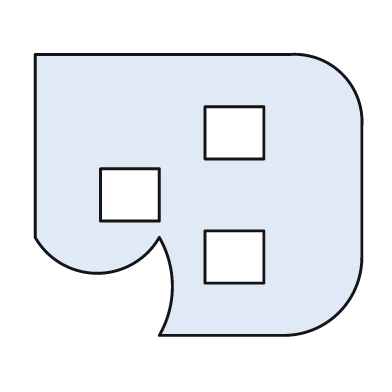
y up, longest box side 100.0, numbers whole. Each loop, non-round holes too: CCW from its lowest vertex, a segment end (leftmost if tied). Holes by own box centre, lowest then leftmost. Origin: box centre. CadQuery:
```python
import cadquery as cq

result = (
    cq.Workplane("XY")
    .moveTo(-12.0, -43.0)
    .lineTo(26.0, -43.0)
    .threePointArc((43.0, -36.0), (50.0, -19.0))
    .lineTo(50.0, 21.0)
    .threePointArc((44.0, 37.0), (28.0, 43.0))
    .lineTo(-50.0, 43.0)
    .lineTo(-50.0, -13.0)
    .threePointArc((-31.0, -24.0), (-12.0, -13.0))
    .threePointArc((-8.0, -28.0), (-12.0, -43.0))
    .close()
    .moveTo(2.0, -27.0)
    .lineTo(20.0, -27.0)
    .lineTo(20.0, -11.0)
    .lineTo(2.0, -11.0)
    .close()
    .moveTo(-30.0, -8.0)
    .lineTo(-12.0, -8.0)
    .lineTo(-12.0, 8.0)
    .lineTo(-30.0, 8.0)
    .close()
    .moveTo(2.0, 11.0)
    .lineTo(20.0, 11.0)
    .lineTo(20.0, 27.0)
    .lineTo(2.0, 27.0)
    .close()
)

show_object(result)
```